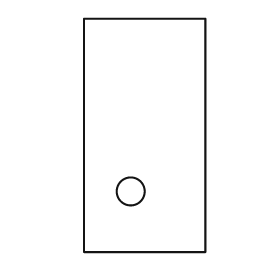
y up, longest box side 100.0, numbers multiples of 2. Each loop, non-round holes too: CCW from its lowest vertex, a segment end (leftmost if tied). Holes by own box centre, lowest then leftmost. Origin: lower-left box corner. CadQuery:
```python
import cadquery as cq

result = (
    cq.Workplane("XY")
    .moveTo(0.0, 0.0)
    .lineTo(52.0, 0.0)
    .lineTo(52.0, 100.0)
    .lineTo(0.0, 100.0)
    .close()
    .moveTo(20.0, 26.0)
    .circle(6.0)
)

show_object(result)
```